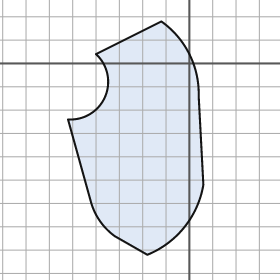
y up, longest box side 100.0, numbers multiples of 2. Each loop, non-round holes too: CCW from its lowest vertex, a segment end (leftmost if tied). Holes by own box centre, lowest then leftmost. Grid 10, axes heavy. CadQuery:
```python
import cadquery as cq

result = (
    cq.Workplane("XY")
    .moveTo(-18.0, -82.0)
    .threePointArc((-2.0, -70.0), (6.0, -52.0))
    .lineTo(4.0, -14.0)
    .threePointArc((0.0, 4.0), (-12.0, 18.0))
    .lineTo(-40.0, 4.0)
    .threePointArc((-36.0, -14.0), (-52.0, -24.0))
    .lineTo(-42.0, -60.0)
    .threePointArc((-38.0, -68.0), (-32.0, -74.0))
    .close()
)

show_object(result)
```